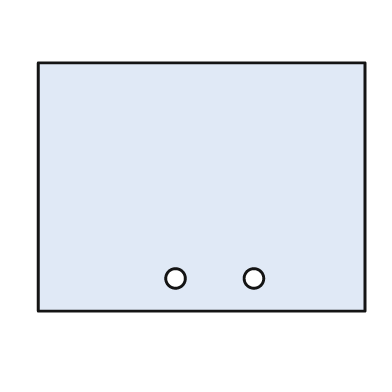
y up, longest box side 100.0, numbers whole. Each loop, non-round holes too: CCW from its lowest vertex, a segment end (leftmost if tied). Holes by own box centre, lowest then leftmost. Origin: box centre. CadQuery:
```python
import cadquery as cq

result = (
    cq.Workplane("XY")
    .moveTo(-50.0, -38.0)
    .lineTo(50.0, -38.0)
    .lineTo(50.0, 38.0)
    .lineTo(-50.0, 38.0)
    .close()
    .moveTo(-8.0, -28.0)
    .circle(3.0)
    .moveTo(16.0, -28.0)
    .circle(3.0)
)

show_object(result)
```